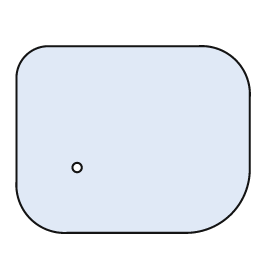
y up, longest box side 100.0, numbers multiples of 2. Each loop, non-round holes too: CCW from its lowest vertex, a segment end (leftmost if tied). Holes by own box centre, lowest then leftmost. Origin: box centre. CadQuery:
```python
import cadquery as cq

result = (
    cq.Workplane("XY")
    .moveTo(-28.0, -40.0)
    .lineTo(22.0, -40.0)
    .threePointArc((42.0, -32.0), (50.0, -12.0))
    .lineTo(50.0, 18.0)
    .threePointArc((44.0, 34.0), (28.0, 40.0))
    .lineTo(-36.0, 40.0)
    .threePointArc((-46.0, 36.0), (-50.0, 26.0))
    .lineTo(-50.0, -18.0)
    .threePointArc((-44.0, -34.0), (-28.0, -40.0))
    .close()
    .moveTo(-24.0, -12.0)
    .circle(2.0)
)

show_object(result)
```